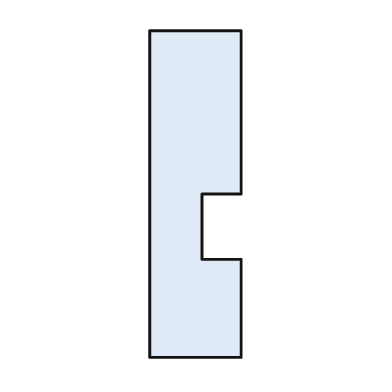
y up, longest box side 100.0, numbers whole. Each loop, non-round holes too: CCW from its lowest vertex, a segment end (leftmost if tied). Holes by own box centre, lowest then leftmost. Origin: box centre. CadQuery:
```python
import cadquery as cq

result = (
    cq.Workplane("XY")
    .moveTo(-14.0, -50.0)
    .lineTo(14.0, -50.0)
    .lineTo(14.0, -20.0)
    .lineTo(2.0, -20.0)
    .lineTo(2.0, 0.0)
    .lineTo(14.0, 0.0)
    .lineTo(14.0, 50.0)
    .lineTo(-14.0, 50.0)
    .close()
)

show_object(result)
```